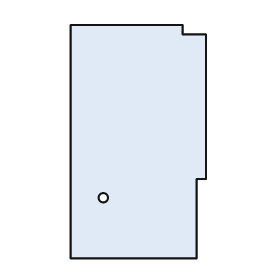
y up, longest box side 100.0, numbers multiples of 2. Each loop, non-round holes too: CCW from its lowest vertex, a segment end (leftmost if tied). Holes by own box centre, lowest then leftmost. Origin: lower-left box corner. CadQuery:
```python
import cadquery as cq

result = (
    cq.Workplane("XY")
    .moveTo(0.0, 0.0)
    .lineTo(54.0, 0.0)
    .lineTo(54.0, 34.0)
    .lineTo(58.0, 34.0)
    .lineTo(58.0, 96.0)
    .lineTo(48.0, 96.0)
    .lineTo(48.0, 100.0)
    .lineTo(0.0, 100.0)
    .close()
    .moveTo(14.0, 26.0)
    .circle(2.0)
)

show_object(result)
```